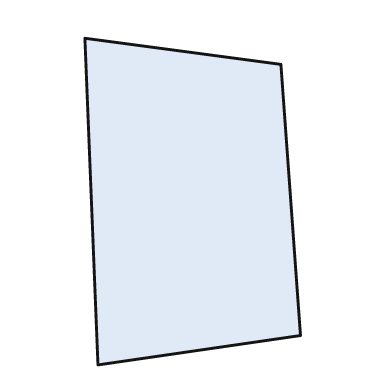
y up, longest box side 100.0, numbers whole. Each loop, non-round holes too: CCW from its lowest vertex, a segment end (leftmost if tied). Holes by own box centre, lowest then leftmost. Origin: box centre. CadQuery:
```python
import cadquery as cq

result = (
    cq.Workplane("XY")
    .moveTo(-29.0, -50.0)
    .lineTo(33.0, -41.0)
    .lineTo(27.0, 42.0)
    .lineTo(-33.0, 50.0)
    .close()
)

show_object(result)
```